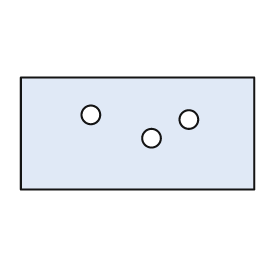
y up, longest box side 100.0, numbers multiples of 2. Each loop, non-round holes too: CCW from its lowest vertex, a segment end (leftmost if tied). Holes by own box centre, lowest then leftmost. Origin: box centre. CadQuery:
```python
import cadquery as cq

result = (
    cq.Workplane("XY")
    .moveTo(-50.0, -24.0)
    .lineTo(50.0, -24.0)
    .lineTo(50.0, 24.0)
    .lineTo(-50.0, 24.0)
    .close()
    .moveTo(6.0, -2.0)
    .circle(4.0)
    .moveTo(22.0, 6.0)
    .circle(4.0)
    .moveTo(-20.0, 8.0)
    .circle(4.0)
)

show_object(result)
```